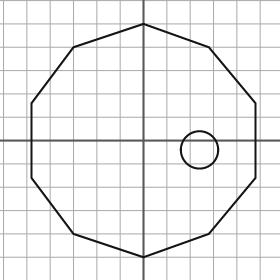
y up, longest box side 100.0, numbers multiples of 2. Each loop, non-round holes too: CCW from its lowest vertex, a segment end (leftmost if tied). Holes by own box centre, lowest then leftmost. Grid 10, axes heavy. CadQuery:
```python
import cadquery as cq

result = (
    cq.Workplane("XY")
    .moveTo(0.0, -50.0)
    .lineTo(28.0, -40.0)
    .lineTo(48.0, -16.0)
    .lineTo(48.0, 16.0)
    .lineTo(28.0, 40.0)
    .lineTo(0.0, 50.0)
    .lineTo(-30.0, 40.0)
    .lineTo(-48.0, 16.0)
    .lineTo(-48.0, -16.0)
    .lineTo(-30.0, -40.0)
    .close()
    .moveTo(24.0, -4.0)
    .circle(8.0)
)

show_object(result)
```